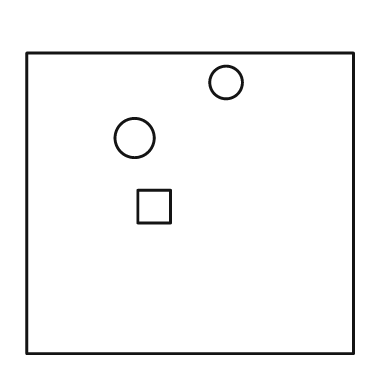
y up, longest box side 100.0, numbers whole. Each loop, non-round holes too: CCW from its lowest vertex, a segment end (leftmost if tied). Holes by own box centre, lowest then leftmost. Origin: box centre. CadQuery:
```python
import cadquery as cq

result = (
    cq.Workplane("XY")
    .moveTo(-50.0, -46.0)
    .lineTo(50.0, -46.0)
    .lineTo(50.0, 46.0)
    .lineTo(-50.0, 46.0)
    .close()
    .moveTo(-16.0, -6.0)
    .lineTo(-6.0, -6.0)
    .lineTo(-6.0, 4.0)
    .lineTo(-16.0, 4.0)
    .close()
    .moveTo(-17.0, 20.0)
    .circle(6.0)
    .moveTo(11.0, 37.0)
    .circle(5.0)
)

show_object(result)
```